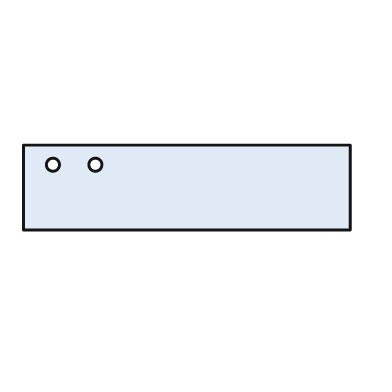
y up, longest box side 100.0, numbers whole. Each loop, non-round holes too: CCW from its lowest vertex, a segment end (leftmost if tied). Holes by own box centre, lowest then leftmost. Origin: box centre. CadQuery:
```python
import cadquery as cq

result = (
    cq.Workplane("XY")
    .moveTo(-50.0, -13.0)
    .lineTo(50.0, -13.0)
    .lineTo(50.0, 13.0)
    .lineTo(-50.0, 13.0)
    .close()
    .moveTo(-41.0, 7.0)
    .circle(2.0)
    .moveTo(-28.0, 7.0)
    .circle(2.0)
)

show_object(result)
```